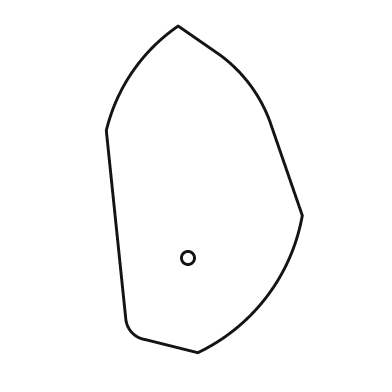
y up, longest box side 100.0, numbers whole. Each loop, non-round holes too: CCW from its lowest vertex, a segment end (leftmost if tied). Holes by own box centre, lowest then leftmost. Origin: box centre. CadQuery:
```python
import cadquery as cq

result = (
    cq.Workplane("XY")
    .moveTo(-2.0, -50.0)
    .threePointArc((19.0, -33.0), (30.0, -8.0))
    .lineTo(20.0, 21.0)
    .threePointArc((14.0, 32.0), (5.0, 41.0))
    .lineTo(-8.0, 50.0)
    .threePointArc((-22.0, 36.0), (-30.0, 18.0))
    .lineTo(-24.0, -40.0)
    .threePointArc((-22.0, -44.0), (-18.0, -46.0))
    .close()
    .moveTo(-5.0, -21.0)
    .circle(2.0)
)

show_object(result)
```